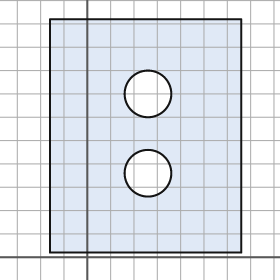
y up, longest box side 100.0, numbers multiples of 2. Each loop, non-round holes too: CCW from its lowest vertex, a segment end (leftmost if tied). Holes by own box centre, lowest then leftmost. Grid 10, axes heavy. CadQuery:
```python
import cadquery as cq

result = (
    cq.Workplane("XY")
    .moveTo(-16.0, 2.0)
    .lineTo(66.0, 2.0)
    .lineTo(66.0, 102.0)
    .lineTo(-16.0, 102.0)
    .close()
    .moveTo(26.0, 36.0)
    .circle(10.0)
    .moveTo(26.0, 70.0)
    .circle(10.0)
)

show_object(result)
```